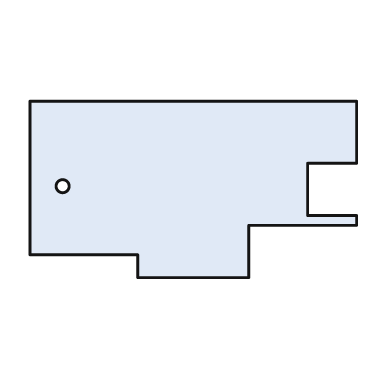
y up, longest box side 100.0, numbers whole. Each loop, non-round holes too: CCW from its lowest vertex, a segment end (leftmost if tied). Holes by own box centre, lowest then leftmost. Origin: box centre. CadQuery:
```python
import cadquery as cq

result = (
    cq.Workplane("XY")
    .moveTo(-17.0, -27.0)
    .lineTo(17.0, -27.0)
    .lineTo(17.0, -11.0)
    .lineTo(50.0, -11.0)
    .lineTo(50.0, -8.0)
    .lineTo(35.0, -8.0)
    .lineTo(35.0, 8.0)
    .lineTo(50.0, 8.0)
    .lineTo(50.0, 27.0)
    .lineTo(-50.0, 27.0)
    .lineTo(-50.0, -20.0)
    .lineTo(-17.0, -20.0)
    .close()
    .moveTo(-40.0, 1.0)
    .circle(2.0)
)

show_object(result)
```